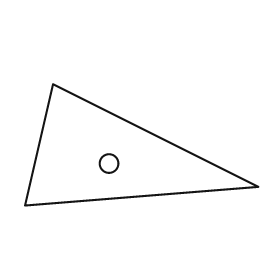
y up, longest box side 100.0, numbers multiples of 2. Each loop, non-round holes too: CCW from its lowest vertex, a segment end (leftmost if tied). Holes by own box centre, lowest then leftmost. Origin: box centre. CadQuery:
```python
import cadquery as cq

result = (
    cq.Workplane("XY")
    .moveTo(-50.0, -26.0)
    .lineTo(50.0, -18.0)
    .lineTo(-38.0, 26.0)
    .close()
    .moveTo(-14.0, -8.0)
    .circle(4.0)
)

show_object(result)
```